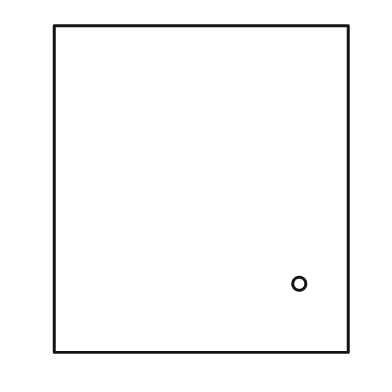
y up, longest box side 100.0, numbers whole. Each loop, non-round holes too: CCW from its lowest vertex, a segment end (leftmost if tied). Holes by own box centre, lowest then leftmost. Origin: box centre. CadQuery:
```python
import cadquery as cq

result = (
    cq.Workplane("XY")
    .moveTo(-45.0, -50.0)
    .lineTo(45.0, -50.0)
    .lineTo(45.0, 50.0)
    .lineTo(-45.0, 50.0)
    .close()
    .moveTo(30.0, -29.0)
    .circle(2.0)
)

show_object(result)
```